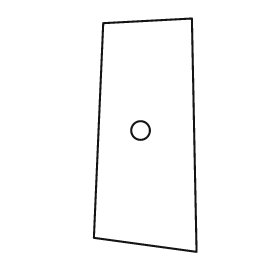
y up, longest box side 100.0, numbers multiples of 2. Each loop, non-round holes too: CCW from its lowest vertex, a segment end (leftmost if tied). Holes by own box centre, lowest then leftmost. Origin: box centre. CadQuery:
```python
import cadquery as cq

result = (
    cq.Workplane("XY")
    .moveTo(22.0, -50.0)
    .lineTo(20.0, 50.0)
    .lineTo(-18.0, 48.0)
    .lineTo(-22.0, -44.0)
    .close()
    .moveTo(-2.0, 2.0)
    .circle(4.0)
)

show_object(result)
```